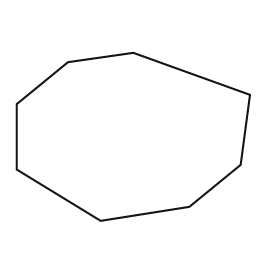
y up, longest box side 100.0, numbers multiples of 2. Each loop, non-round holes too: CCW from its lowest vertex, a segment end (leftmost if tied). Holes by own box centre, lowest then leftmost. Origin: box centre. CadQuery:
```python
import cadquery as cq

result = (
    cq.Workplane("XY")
    .moveTo(-14.0, -36.0)
    .lineTo(24.0, -30.0)
    .lineTo(46.0, -12.0)
    .lineTo(50.0, 18.0)
    .lineTo(0.0, 36.0)
    .lineTo(-28.0, 32.0)
    .lineTo(-50.0, 14.0)
    .lineTo(-50.0, -14.0)
    .close()
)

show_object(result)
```